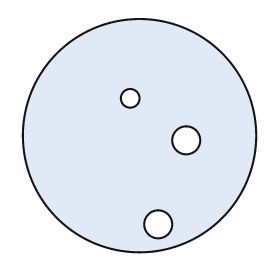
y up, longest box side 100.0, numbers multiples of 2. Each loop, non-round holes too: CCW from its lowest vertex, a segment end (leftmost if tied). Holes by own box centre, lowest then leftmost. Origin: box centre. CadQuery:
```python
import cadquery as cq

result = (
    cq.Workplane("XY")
    .moveTo(0.0, 0.0)
    .circle(50.0)
    .moveTo(8.0, -38.0)
    .circle(6.0)
    .moveTo(20.0, -2.0)
    .circle(6.0)
    .moveTo(-4.0, 16.0)
    .circle(4.0)
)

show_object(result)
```